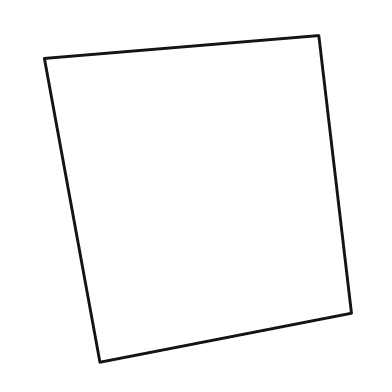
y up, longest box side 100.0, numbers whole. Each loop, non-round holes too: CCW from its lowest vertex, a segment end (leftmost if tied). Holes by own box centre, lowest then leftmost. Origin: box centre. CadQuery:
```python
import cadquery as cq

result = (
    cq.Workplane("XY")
    .moveTo(-30.0, -50.0)
    .lineTo(47.0, -35.0)
    .lineTo(37.0, 50.0)
    .lineTo(-47.0, 43.0)
    .close()
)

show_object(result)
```